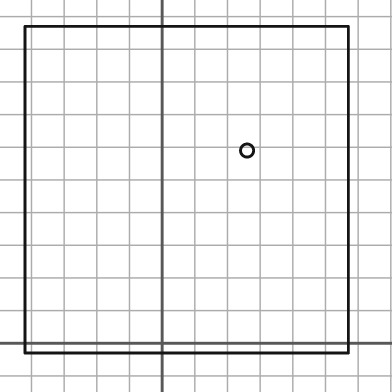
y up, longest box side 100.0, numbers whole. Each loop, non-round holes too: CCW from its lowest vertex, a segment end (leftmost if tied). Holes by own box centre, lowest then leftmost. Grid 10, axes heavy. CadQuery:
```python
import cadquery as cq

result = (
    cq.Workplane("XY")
    .moveTo(-42.0, -3.0)
    .lineTo(57.0, -3.0)
    .lineTo(57.0, 97.0)
    .lineTo(-42.0, 97.0)
    .close()
    .moveTo(26.0, 59.0)
    .circle(2.0)
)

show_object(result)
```